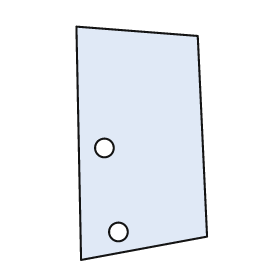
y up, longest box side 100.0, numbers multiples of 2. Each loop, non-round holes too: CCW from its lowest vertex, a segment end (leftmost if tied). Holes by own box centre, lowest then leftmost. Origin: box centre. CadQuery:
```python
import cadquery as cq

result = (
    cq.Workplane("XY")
    .moveTo(-26.0, -50.0)
    .lineTo(28.0, -40.0)
    .lineTo(24.0, 46.0)
    .lineTo(-28.0, 50.0)
    .close()
    .moveTo(-10.0, -38.0)
    .circle(4.0)
    .moveTo(-16.0, -2.0)
    .circle(4.0)
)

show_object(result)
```